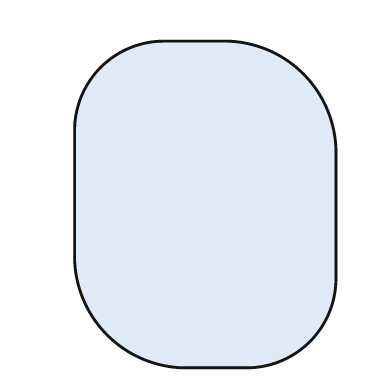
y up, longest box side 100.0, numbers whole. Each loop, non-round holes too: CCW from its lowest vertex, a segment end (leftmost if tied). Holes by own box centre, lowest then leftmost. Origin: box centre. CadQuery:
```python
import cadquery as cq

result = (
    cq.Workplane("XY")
    .moveTo(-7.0, -50.0)
    .lineTo(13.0, -50.0)
    .threePointArc((32.0, -42.0), (40.0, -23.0))
    .lineTo(40.0, 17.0)
    .threePointArc((30.0, 40.0), (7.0, 50.0))
    .lineTo(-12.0, 50.0)
    .threePointArc((-32.0, 42.0), (-40.0, 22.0))
    .lineTo(-40.0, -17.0)
    .threePointArc((-30.0, -40.0), (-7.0, -50.0))
    .close()
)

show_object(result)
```